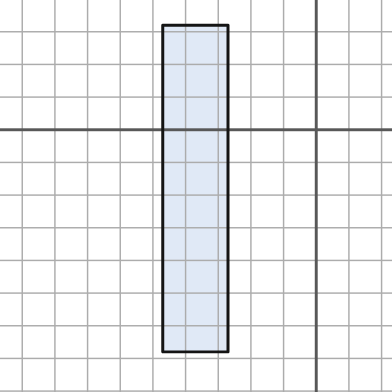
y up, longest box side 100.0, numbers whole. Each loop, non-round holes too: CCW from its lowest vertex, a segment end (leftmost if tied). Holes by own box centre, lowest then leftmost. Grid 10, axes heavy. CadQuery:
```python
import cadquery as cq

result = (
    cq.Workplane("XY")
    .moveTo(-47.0, -68.0)
    .lineTo(-27.0, -68.0)
    .lineTo(-27.0, 32.0)
    .lineTo(-47.0, 32.0)
    .close()
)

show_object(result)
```